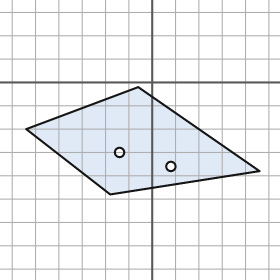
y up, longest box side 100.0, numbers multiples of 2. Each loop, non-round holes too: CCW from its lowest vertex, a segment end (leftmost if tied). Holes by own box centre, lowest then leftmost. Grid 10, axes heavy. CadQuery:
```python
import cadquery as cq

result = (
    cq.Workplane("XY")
    .moveTo(-18.0, -48.0)
    .lineTo(46.0, -38.0)
    .lineTo(-6.0, -2.0)
    .lineTo(-54.0, -20.0)
    .close()
    .moveTo(8.0, -36.0)
    .circle(2.0)
    .moveTo(-14.0, -30.0)
    .circle(2.0)
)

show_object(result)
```